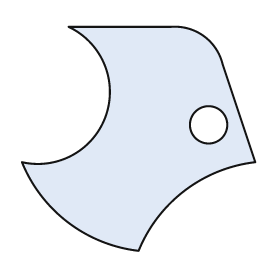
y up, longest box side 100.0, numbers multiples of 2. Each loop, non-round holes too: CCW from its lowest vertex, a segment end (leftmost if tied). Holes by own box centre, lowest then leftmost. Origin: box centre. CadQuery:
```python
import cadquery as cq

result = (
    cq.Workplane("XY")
    .moveTo(0.0, -48.0)
    .threePointArc((20.0, -22.0), (50.0, -10.0))
    .lineTo(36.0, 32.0)
    .threePointArc((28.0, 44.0), (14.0, 48.0))
    .lineTo(-30.0, 48.0)
    .threePointArc((-14.0, 10.0), (-50.0, -10.0))
    .threePointArc((-30.0, -36.0), (0.0, -48.0))
    .close()
    .moveTo(30.0, 6.0)
    .circle(8.0)
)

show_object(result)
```